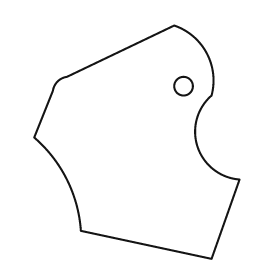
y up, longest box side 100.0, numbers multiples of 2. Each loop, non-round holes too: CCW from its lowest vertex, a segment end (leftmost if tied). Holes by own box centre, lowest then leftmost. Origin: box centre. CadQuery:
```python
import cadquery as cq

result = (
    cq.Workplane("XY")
    .moveTo(32.0, -50.0)
    .lineTo(44.0, -16.0)
    .threePointArc((26.0, -2.0), (32.0, 20.0))
    .threePointArc((30.0, 38.0), (16.0, 50.0))
    .lineTo(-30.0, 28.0)
    .threePointArc((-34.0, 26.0), (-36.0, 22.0))
    .lineTo(-44.0, 2.0)
    .threePointArc((-30.0, -16.0), (-24.0, -38.0))
    .close()
    .moveTo(20.0, 24.0)
    .circle(4.0)
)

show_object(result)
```